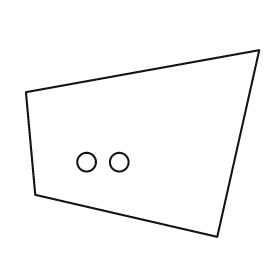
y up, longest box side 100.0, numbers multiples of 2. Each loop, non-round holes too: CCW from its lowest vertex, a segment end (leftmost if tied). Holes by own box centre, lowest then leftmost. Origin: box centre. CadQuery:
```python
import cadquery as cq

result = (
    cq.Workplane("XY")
    .moveTo(32.0, -40.0)
    .lineTo(50.0, 40.0)
    .lineTo(-50.0, 22.0)
    .lineTo(-46.0, -22.0)
    .close()
    .moveTo(-24.0, -8.0)
    .circle(4.0)
    .moveTo(-10.0, -8.0)
    .circle(4.0)
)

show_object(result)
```